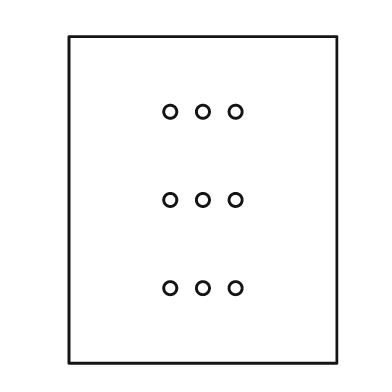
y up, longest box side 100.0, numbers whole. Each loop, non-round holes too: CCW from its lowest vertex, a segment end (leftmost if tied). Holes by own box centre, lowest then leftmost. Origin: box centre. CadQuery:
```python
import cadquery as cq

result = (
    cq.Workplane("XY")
    .moveTo(-41.0, -50.0)
    .lineTo(41.0, -50.0)
    .lineTo(41.0, 50.0)
    .lineTo(-41.0, 50.0)
    .close()
    .moveTo(-10.0, -27.0)
    .circle(2.0)
    .moveTo(0.0, -27.0)
    .circle(2.0)
    .moveTo(10.0, -27.0)
    .circle(2.0)
    .moveTo(-10.0, 0.0)
    .circle(2.0)
    .moveTo(0.0, 0.0)
    .circle(2.0)
    .moveTo(10.0, 0.0)
    .circle(2.0)
    .moveTo(-10.0, 27.0)
    .circle(2.0)
    .moveTo(0.0, 27.0)
    .circle(2.0)
    .moveTo(10.0, 27.0)
    .circle(2.0)
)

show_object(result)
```